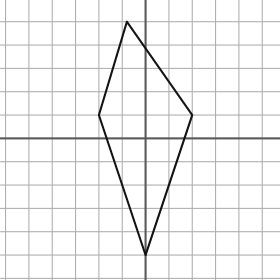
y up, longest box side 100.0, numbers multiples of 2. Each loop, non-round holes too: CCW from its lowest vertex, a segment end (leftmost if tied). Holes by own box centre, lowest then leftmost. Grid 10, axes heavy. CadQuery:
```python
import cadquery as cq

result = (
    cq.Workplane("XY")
    .moveTo(0.0, -50.0)
    .lineTo(20.0, 10.0)
    .lineTo(-8.0, 50.0)
    .lineTo(-20.0, 10.0)
    .close()
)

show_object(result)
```